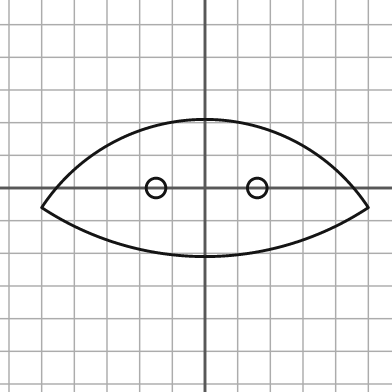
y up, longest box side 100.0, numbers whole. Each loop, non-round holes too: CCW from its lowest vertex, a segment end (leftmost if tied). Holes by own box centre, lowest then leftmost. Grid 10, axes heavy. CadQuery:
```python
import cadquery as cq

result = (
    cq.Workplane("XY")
    .moveTo(-50.0, -6.0)
    .threePointArc((0.0, -21.0), (50.0, -6.0))
    .threePointArc((0.0, 21.0), (-50.0, -6.0))
    .close()
    .moveTo(-15.0, 0.0)
    .circle(3.0)
    .moveTo(16.0, 0.0)
    .circle(3.0)
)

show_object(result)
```